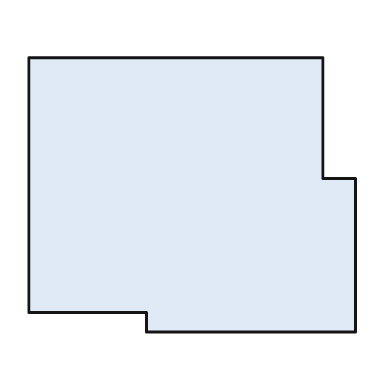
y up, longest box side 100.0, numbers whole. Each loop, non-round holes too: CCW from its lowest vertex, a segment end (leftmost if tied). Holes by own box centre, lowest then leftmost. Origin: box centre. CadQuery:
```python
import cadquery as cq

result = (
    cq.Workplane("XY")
    .moveTo(-14.0, -42.0)
    .lineTo(50.0, -42.0)
    .lineTo(50.0, 5.0)
    .lineTo(40.0, 5.0)
    .lineTo(40.0, 42.0)
    .lineTo(-50.0, 42.0)
    .lineTo(-50.0, -36.0)
    .lineTo(-14.0, -36.0)
    .close()
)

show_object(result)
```